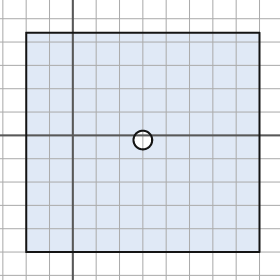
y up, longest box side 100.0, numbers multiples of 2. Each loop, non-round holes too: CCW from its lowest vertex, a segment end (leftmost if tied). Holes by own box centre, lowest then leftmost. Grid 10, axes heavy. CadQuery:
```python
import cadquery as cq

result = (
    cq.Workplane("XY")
    .moveTo(-20.0, -50.0)
    .lineTo(80.0, -50.0)
    .lineTo(80.0, 44.0)
    .lineTo(-20.0, 44.0)
    .close()
    .moveTo(30.0, -2.0)
    .circle(4.0)
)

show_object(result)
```